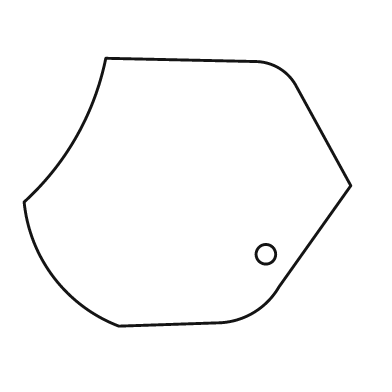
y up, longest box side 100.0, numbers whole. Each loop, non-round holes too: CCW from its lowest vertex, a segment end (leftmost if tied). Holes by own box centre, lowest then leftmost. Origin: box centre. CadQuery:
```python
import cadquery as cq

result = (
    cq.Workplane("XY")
    .moveTo(-21.0, -41.0)
    .lineTo(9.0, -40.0)
    .threePointArc((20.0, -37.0), (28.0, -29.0))
    .lineTo(50.0, 2.0)
    .lineTo(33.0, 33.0)
    .threePointArc((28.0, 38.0), (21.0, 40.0))
    .lineTo(-25.0, 41.0)
    .threePointArc((-34.0, 17.0), (-50.0, -3.0))
    .threePointArc((-41.0, -26.0), (-21.0, -41.0))
    .close()
    .moveTo(24.0, -19.0)
    .circle(3.0)
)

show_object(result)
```